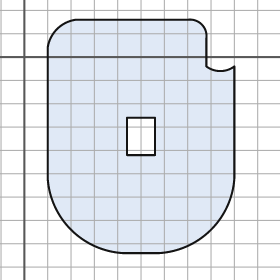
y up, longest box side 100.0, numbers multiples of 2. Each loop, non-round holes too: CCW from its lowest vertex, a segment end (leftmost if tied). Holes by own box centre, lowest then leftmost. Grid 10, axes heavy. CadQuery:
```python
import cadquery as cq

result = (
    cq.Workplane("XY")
    .moveTo(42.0, -84.0)
    .lineTo(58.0, -84.0)
    .threePointArc((80.0, -74.0), (90.0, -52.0))
    .lineTo(90.0, -4.0)
    .threePointArc((84.0, -6.0), (78.0, -4.0))
    .lineTo(78.0, 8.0)
    .threePointArc((76.0, 14.0), (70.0, 16.0))
    .lineTo(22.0, 16.0)
    .threePointArc((14.0, 12.0), (10.0, 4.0))
    .lineTo(10.0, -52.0)
    .threePointArc((20.0, -74.0), (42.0, -84.0))
    .close()
    .moveTo(44.0, -42.0)
    .lineTo(56.0, -42.0)
    .lineTo(56.0, -26.0)
    .lineTo(44.0, -26.0)
    .close()
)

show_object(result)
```